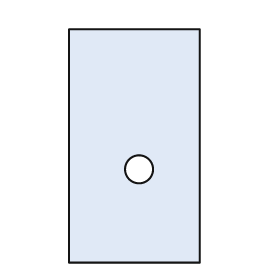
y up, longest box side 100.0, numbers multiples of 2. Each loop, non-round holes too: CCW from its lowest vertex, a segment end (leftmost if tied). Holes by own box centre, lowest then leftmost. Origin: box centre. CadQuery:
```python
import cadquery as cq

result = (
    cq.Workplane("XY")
    .moveTo(-28.0, -50.0)
    .lineTo(28.0, -50.0)
    .lineTo(28.0, 50.0)
    .lineTo(-28.0, 50.0)
    .close()
    .moveTo(2.0, -10.0)
    .circle(6.0)
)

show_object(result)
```